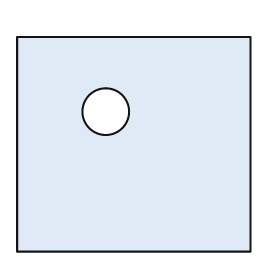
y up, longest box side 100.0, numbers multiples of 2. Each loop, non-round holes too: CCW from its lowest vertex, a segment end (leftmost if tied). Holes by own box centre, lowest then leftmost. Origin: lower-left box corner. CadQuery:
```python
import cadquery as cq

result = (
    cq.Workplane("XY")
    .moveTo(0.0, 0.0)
    .lineTo(100.0, 0.0)
    .lineTo(100.0, 92.0)
    .lineTo(0.0, 92.0)
    .close()
    .moveTo(38.0, 60.0)
    .circle(10.0)
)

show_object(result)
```